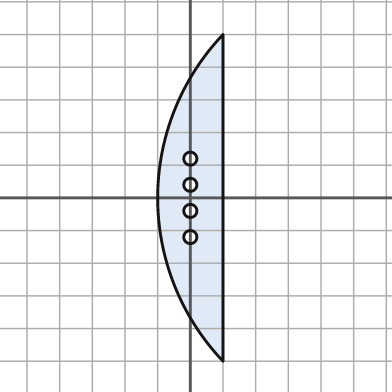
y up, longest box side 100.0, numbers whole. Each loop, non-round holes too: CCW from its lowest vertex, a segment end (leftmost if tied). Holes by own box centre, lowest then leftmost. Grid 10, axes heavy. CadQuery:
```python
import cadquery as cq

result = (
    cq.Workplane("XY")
    .moveTo(10.0, -50.0)
    .lineTo(10.0, 50.0)
    .threePointArc((-10.0, 0.0), (10.0, -50.0))
    .close()
    .moveTo(0.0, -12.0)
    .circle(2.0)
    .moveTo(0.0, -4.0)
    .circle(2.0)
    .moveTo(0.0, 4.0)
    .circle(2.0)
    .moveTo(0.0, 12.0)
    .circle(2.0)
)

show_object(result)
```